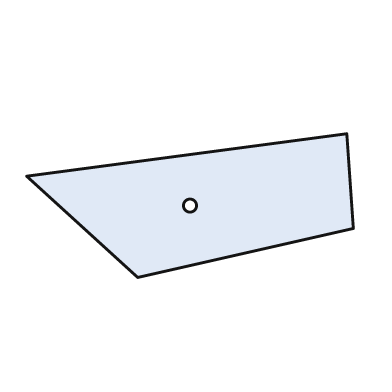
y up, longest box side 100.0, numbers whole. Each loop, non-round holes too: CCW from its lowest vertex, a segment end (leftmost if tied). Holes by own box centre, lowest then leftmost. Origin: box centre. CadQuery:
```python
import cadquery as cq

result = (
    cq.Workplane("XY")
    .moveTo(-16.0, -22.0)
    .lineTo(50.0, -7.0)
    .lineTo(48.0, 22.0)
    .lineTo(-50.0, 9.0)
    .close()
    .moveTo(0.0, 0.0)
    .circle(2.0)
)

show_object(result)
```